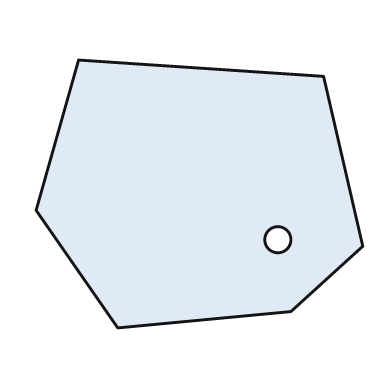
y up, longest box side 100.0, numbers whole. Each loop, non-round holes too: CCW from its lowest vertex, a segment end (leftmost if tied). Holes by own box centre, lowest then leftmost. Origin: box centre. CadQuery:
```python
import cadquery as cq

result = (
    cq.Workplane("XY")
    .moveTo(-25.0, -41.0)
    .lineTo(28.0, -36.0)
    .lineTo(50.0, -16.0)
    .lineTo(38.0, 36.0)
    .lineTo(-37.0, 41.0)
    .lineTo(-50.0, -5.0)
    .close()
    .moveTo(24.0, -14.0)
    .circle(4.0)
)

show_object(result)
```